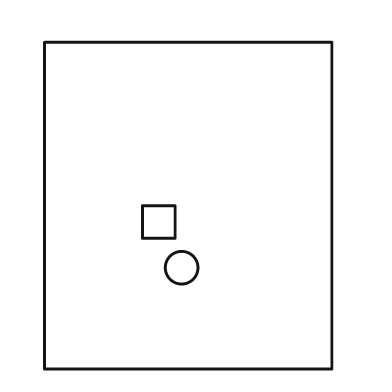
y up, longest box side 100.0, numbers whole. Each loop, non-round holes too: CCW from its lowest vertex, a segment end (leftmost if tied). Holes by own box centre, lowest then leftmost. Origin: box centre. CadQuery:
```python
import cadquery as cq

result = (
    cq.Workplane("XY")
    .moveTo(-44.0, -50.0)
    .lineTo(44.0, -50.0)
    .lineTo(44.0, 50.0)
    .lineTo(-44.0, 50.0)
    .close()
    .moveTo(-2.0, -19.0)
    .circle(5.0)
    .moveTo(-14.0, -10.0)
    .lineTo(-4.0, -10.0)
    .lineTo(-4.0, 0.0)
    .lineTo(-14.0, 0.0)
    .close()
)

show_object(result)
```